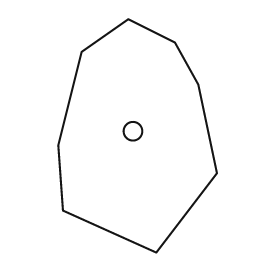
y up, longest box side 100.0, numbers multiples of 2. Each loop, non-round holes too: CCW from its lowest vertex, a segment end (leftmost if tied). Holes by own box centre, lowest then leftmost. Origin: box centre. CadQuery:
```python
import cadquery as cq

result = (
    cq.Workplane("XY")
    .moveTo(8.0, -50.0)
    .lineTo(34.0, -16.0)
    .lineTo(26.0, 22.0)
    .lineTo(16.0, 40.0)
    .lineTo(-4.0, 50.0)
    .lineTo(-24.0, 36.0)
    .lineTo(-34.0, -4.0)
    .lineTo(-32.0, -32.0)
    .close()
    .moveTo(-2.0, 2.0)
    .circle(4.0)
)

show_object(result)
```